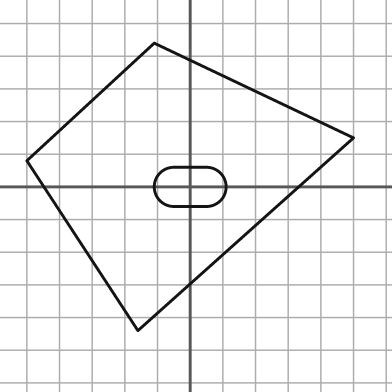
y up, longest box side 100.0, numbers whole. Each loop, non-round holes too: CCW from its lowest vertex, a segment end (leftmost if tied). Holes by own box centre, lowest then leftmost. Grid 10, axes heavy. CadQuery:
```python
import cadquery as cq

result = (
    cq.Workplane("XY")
    .moveTo(-16.0, -44.0)
    .lineTo(50.0, 15.0)
    .lineTo(-11.0, 44.0)
    .lineTo(-50.0, 8.0)
    .close()
    .moveTo(-5.0, -6.0)
    .lineTo(5.0, -6.0)
    .threePointArc((11.0, 0.0), (5.0, 6.0))
    .lineTo(-5.0, 6.0)
    .threePointArc((-11.0, 0.0), (-5.0, -6.0))
    .close()
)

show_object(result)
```